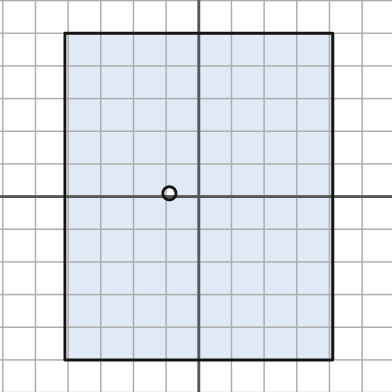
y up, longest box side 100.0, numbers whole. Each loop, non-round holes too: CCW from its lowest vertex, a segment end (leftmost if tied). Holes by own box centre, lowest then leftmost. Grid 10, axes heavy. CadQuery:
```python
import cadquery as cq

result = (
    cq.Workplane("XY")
    .moveTo(-41.0, -50.0)
    .lineTo(41.0, -50.0)
    .lineTo(41.0, 50.0)
    .lineTo(-41.0, 50.0)
    .close()
    .moveTo(-9.0, 1.0)
    .circle(2.0)
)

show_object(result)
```